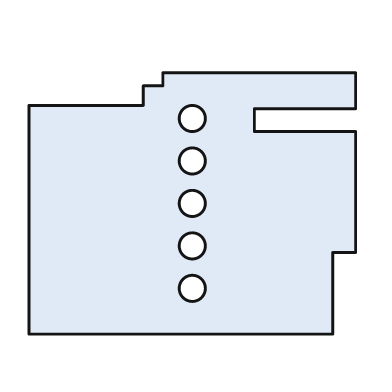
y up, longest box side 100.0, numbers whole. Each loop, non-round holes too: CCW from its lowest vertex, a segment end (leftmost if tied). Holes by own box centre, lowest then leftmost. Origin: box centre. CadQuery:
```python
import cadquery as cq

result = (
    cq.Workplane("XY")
    .moveTo(-50.0, -40.0)
    .lineTo(43.0, -40.0)
    .lineTo(43.0, -15.0)
    .lineTo(50.0, -15.0)
    .lineTo(50.0, 22.0)
    .lineTo(19.0, 22.0)
    .lineTo(19.0, 29.0)
    .lineTo(50.0, 29.0)
    .lineTo(50.0, 40.0)
    .lineTo(-9.0, 40.0)
    .lineTo(-9.0, 36.0)
    .lineTo(-15.0, 36.0)
    .lineTo(-15.0, 30.0)
    .lineTo(-50.0, 30.0)
    .close()
    .moveTo(0.0, -26.0)
    .circle(4.0)
    .moveTo(0.0, -13.0)
    .circle(4.0)
    .moveTo(0.0, 0.0)
    .circle(4.0)
    .moveTo(0.0, 13.0)
    .circle(4.0)
    .moveTo(0.0, 26.0)
    .circle(4.0)
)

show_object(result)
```